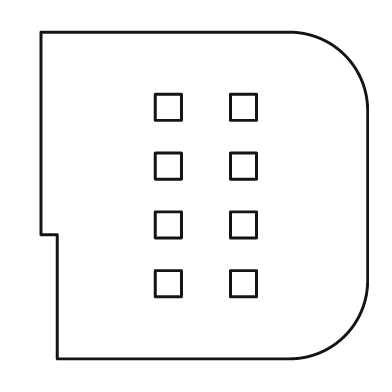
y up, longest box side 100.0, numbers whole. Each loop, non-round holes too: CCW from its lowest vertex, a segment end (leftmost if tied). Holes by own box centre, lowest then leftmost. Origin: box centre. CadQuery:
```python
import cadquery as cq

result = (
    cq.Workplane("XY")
    .moveTo(-45.0, -50.0)
    .lineTo(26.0, -50.0)
    .threePointArc((43.0, -43.0), (50.0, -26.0))
    .lineTo(50.0, 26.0)
    .threePointArc((43.0, 43.0), (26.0, 50.0))
    .lineTo(-50.0, 50.0)
    .lineTo(-50.0, -12.0)
    .lineTo(-45.0, -12.0)
    .close()
    .moveTo(-15.0, -31.0)
    .lineTo(-7.0, -31.0)
    .lineTo(-7.0, -23.0)
    .lineTo(-15.0, -23.0)
    .close()
    .moveTo(8.0, -31.0)
    .lineTo(16.0, -31.0)
    .lineTo(16.0, -23.0)
    .lineTo(8.0, -23.0)
    .close()
    .moveTo(-15.0, -13.0)
    .lineTo(-7.0, -13.0)
    .lineTo(-7.0, -5.0)
    .lineTo(-15.0, -5.0)
    .close()
    .moveTo(8.0, -13.0)
    .lineTo(16.0, -13.0)
    .lineTo(16.0, -5.0)
    .lineTo(8.0, -5.0)
    .close()
    .moveTo(-15.0, 5.0)
    .lineTo(-7.0, 5.0)
    .lineTo(-7.0, 13.0)
    .lineTo(-15.0, 13.0)
    .close()
    .moveTo(8.0, 5.0)
    .lineTo(16.0, 5.0)
    .lineTo(16.0, 13.0)
    .lineTo(8.0, 13.0)
    .close()
    .moveTo(-15.0, 23.0)
    .lineTo(-7.0, 23.0)
    .lineTo(-7.0, 31.0)
    .lineTo(-15.0, 31.0)
    .close()
    .moveTo(8.0, 23.0)
    .lineTo(16.0, 23.0)
    .lineTo(16.0, 31.0)
    .lineTo(8.0, 31.0)
    .close()
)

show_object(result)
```